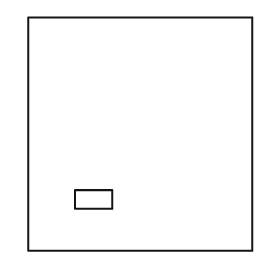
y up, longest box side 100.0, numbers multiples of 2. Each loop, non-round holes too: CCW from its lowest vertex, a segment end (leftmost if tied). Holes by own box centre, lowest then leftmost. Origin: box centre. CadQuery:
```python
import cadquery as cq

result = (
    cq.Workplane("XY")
    .moveTo(-48.0, -50.0)
    .lineTo(48.0, -50.0)
    .lineTo(48.0, 50.0)
    .lineTo(-48.0, 50.0)
    .close()
    .moveTo(-28.0, -32.0)
    .lineTo(-12.0, -32.0)
    .lineTo(-12.0, -24.0)
    .lineTo(-28.0, -24.0)
    .close()
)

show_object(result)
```